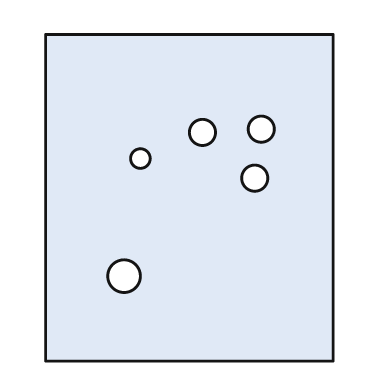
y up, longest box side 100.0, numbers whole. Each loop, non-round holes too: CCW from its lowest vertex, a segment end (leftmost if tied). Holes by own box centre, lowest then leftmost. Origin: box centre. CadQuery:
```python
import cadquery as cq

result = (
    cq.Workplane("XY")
    .moveTo(-44.0, -50.0)
    .lineTo(44.0, -50.0)
    .lineTo(44.0, 50.0)
    .lineTo(-44.0, 50.0)
    .close()
    .moveTo(-20.0, -24.0)
    .circle(5.0)
    .moveTo(20.0, 6.0)
    .circle(4.0)
    .moveTo(-15.0, 12.0)
    .circle(3.0)
    .moveTo(4.0, 20.0)
    .circle(4.0)
    .moveTo(22.0, 21.0)
    .circle(4.0)
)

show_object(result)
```